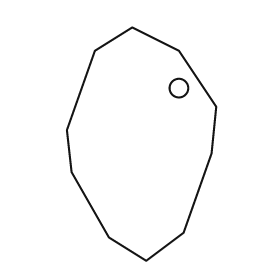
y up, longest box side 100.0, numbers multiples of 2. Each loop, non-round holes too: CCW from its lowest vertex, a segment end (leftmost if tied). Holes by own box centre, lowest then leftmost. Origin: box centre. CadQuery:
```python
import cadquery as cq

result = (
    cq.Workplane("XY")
    .moveTo(2.0, -50.0)
    .lineTo(18.0, -38.0)
    .lineTo(30.0, -4.0)
    .lineTo(32.0, 16.0)
    .lineTo(16.0, 40.0)
    .lineTo(-4.0, 50.0)
    .lineTo(-20.0, 40.0)
    .lineTo(-32.0, 6.0)
    .lineTo(-30.0, -12.0)
    .lineTo(-14.0, -40.0)
    .close()
    .moveTo(16.0, 24.0)
    .circle(4.0)
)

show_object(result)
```